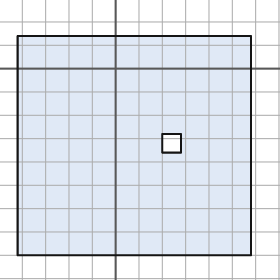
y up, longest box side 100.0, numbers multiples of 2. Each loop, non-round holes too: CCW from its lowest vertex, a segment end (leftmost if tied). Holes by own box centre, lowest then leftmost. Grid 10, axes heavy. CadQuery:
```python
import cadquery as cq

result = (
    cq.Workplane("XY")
    .moveTo(-42.0, -80.0)
    .lineTo(58.0, -80.0)
    .lineTo(58.0, 14.0)
    .lineTo(-42.0, 14.0)
    .close()
    .moveTo(20.0, -36.0)
    .lineTo(28.0, -36.0)
    .lineTo(28.0, -28.0)
    .lineTo(20.0, -28.0)
    .close()
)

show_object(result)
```